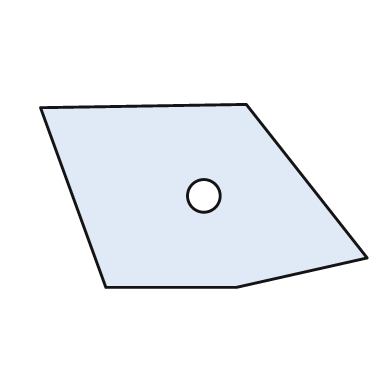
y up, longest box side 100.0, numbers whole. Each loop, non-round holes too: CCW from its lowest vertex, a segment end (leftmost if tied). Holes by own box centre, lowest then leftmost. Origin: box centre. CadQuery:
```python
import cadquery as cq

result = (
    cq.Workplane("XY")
    .moveTo(-30.0, -28.0)
    .lineTo(10.0, -28.0)
    .lineTo(50.0, -19.0)
    .lineTo(13.0, 28.0)
    .lineTo(-50.0, 27.0)
    .close()
    .moveTo(0.0, 0.0)
    .circle(5.0)
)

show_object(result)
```